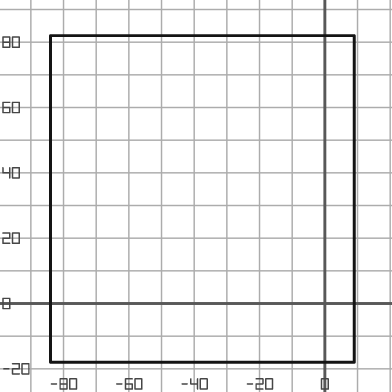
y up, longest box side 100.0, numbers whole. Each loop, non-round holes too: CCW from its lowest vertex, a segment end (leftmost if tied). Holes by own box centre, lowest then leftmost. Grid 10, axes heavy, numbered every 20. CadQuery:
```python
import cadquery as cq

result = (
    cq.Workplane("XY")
    .moveTo(-84.0, -18.0)
    .lineTo(9.0, -18.0)
    .lineTo(9.0, 82.0)
    .lineTo(-84.0, 82.0)
    .close()
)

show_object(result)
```